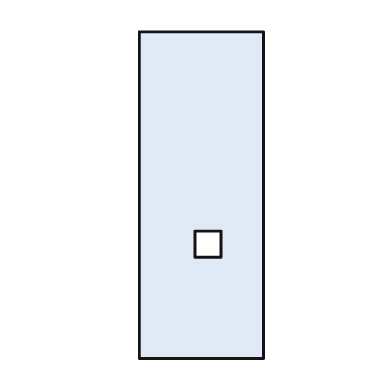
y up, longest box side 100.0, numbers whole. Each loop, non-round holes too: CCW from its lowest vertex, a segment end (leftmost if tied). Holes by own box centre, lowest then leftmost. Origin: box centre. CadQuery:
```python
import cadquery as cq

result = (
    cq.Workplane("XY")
    .moveTo(-19.0, -50.0)
    .lineTo(19.0, -50.0)
    .lineTo(19.0, 50.0)
    .lineTo(-19.0, 50.0)
    .close()
    .moveTo(-2.0, -19.0)
    .lineTo(6.0, -19.0)
    .lineTo(6.0, -11.0)
    .lineTo(-2.0, -11.0)
    .close()
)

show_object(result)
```